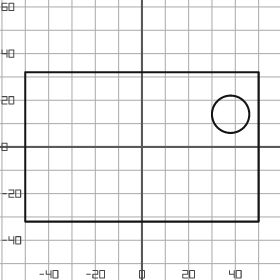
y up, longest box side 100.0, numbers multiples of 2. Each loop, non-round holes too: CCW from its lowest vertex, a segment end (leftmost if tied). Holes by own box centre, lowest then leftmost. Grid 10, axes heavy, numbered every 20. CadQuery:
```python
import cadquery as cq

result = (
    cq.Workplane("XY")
    .moveTo(-50.0, -32.0)
    .lineTo(50.0, -32.0)
    .lineTo(50.0, 32.0)
    .lineTo(-50.0, 32.0)
    .close()
    .moveTo(38.0, 14.0)
    .circle(8.0)
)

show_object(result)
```